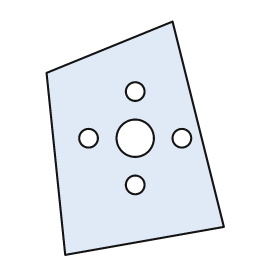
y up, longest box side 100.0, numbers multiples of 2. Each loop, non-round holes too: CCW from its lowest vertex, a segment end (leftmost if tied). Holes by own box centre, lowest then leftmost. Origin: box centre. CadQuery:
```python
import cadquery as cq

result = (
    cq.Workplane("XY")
    .moveTo(-30.0, -50.0)
    .lineTo(38.0, -38.0)
    .lineTo(16.0, 50.0)
    .lineTo(-38.0, 28.0)
    .close()
    .moveTo(0.0, -20.0)
    .circle(4.0)
    .moveTo(-20.0, 0.0)
    .circle(4.0)
    .moveTo(0.0, 0.0)
    .circle(8.0)
    .moveTo(20.0, 0.0)
    .circle(4.0)
    .moveTo(0.0, 20.0)
    .circle(4.0)
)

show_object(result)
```